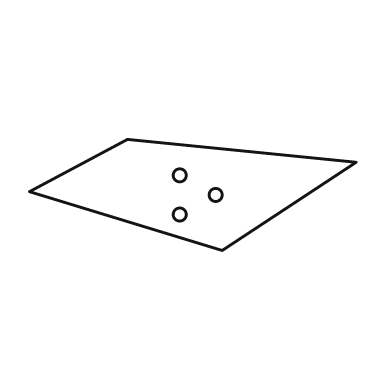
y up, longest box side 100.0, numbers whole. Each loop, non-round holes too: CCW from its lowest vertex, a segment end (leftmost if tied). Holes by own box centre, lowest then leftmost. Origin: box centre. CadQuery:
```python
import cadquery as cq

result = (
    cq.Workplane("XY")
    .moveTo(9.0, -17.0)
    .lineTo(50.0, 10.0)
    .lineTo(-20.0, 17.0)
    .lineTo(-50.0, 1.0)
    .close()
    .moveTo(-4.0, -6.0)
    .circle(2.0)
    .moveTo(7.0, 0.0)
    .circle(2.0)
    .moveTo(-4.0, 6.0)
    .circle(2.0)
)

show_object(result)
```